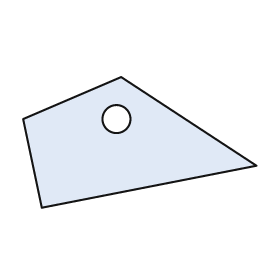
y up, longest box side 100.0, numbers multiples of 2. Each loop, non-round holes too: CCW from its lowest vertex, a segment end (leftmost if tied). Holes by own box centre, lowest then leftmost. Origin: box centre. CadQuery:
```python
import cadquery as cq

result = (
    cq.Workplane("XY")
    .moveTo(-42.0, -28.0)
    .lineTo(50.0, -10.0)
    .lineTo(-8.0, 28.0)
    .lineTo(-50.0, 10.0)
    .close()
    .moveTo(-10.0, 10.0)
    .circle(6.0)
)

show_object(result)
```